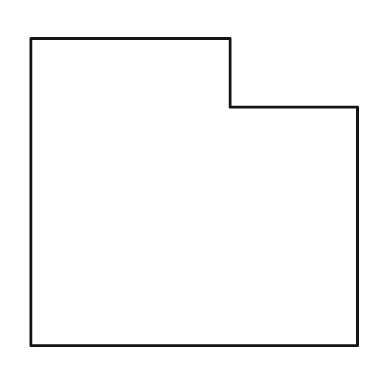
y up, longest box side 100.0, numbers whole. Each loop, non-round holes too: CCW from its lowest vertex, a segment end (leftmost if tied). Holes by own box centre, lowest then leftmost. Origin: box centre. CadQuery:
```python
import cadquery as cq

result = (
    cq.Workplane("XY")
    .moveTo(-50.0, -47.0)
    .lineTo(50.0, -47.0)
    .lineTo(50.0, 26.0)
    .lineTo(11.0, 26.0)
    .lineTo(11.0, 47.0)
    .lineTo(-50.0, 47.0)
    .close()
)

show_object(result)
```